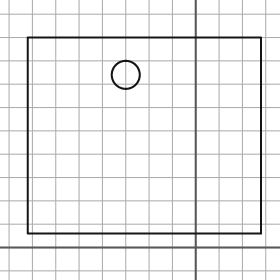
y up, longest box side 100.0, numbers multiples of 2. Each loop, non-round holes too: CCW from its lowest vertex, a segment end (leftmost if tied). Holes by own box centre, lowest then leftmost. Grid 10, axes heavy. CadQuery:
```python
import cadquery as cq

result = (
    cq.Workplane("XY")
    .moveTo(-72.0, 6.0)
    .lineTo(28.0, 6.0)
    .lineTo(28.0, 90.0)
    .lineTo(-72.0, 90.0)
    .close()
    .moveTo(-30.0, 74.0)
    .circle(6.0)
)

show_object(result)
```